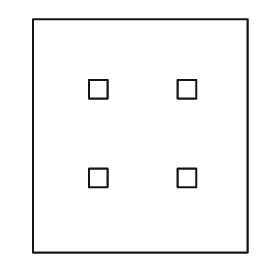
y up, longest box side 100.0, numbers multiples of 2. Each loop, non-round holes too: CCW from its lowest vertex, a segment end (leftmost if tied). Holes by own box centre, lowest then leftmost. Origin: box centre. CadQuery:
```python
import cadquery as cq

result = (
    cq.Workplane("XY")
    .moveTo(-46.0, -50.0)
    .lineTo(46.0, -50.0)
    .lineTo(46.0, 50.0)
    .lineTo(-46.0, 50.0)
    .close()
    .moveTo(-22.0, -22.0)
    .lineTo(-14.0, -22.0)
    .lineTo(-14.0, -14.0)
    .lineTo(-22.0, -14.0)
    .close()
    .moveTo(16.0, -22.0)
    .lineTo(24.0, -22.0)
    .lineTo(24.0, -14.0)
    .lineTo(16.0, -14.0)
    .close()
    .moveTo(-22.0, 16.0)
    .lineTo(-14.0, 16.0)
    .lineTo(-14.0, 24.0)
    .lineTo(-22.0, 24.0)
    .close()
    .moveTo(16.0, 16.0)
    .lineTo(24.0, 16.0)
    .lineTo(24.0, 24.0)
    .lineTo(16.0, 24.0)
    .close()
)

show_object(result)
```